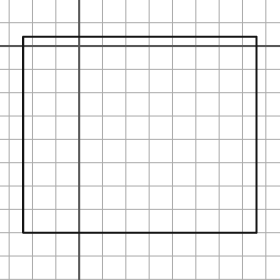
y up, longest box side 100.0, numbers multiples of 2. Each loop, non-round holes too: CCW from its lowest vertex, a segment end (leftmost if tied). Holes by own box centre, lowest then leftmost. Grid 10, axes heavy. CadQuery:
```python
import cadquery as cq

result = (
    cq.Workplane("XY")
    .moveTo(-24.0, -80.0)
    .lineTo(76.0, -80.0)
    .lineTo(76.0, 4.0)
    .lineTo(-24.0, 4.0)
    .close()
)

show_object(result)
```